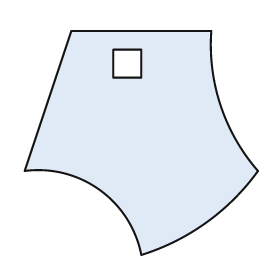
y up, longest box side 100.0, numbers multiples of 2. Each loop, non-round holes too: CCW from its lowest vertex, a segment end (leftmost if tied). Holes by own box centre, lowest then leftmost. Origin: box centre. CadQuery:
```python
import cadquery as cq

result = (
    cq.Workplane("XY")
    .moveTo(0.0, -48.0)
    .threePointArc((28.0, -34.0), (50.0, -12.0))
    .threePointArc((34.0, 16.0), (30.0, 48.0))
    .lineTo(-30.0, 48.0)
    .lineTo(-50.0, -12.0)
    .threePointArc((-18.0, -20.0), (0.0, -48.0))
    .close()
    .moveTo(-12.0, 28.0)
    .lineTo(0.0, 28.0)
    .lineTo(0.0, 40.0)
    .lineTo(-12.0, 40.0)
    .close()
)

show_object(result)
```